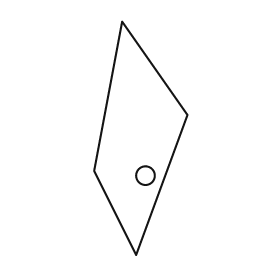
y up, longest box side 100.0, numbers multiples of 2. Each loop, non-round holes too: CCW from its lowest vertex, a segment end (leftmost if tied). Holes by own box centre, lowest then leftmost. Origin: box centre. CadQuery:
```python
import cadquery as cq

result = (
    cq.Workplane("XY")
    .moveTo(-2.0, -50.0)
    .lineTo(20.0, 10.0)
    .lineTo(-8.0, 50.0)
    .lineTo(-20.0, -14.0)
    .close()
    .moveTo(2.0, -16.0)
    .circle(4.0)
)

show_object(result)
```